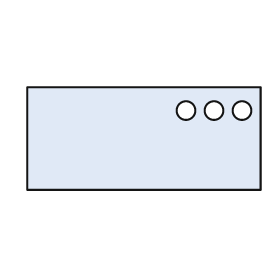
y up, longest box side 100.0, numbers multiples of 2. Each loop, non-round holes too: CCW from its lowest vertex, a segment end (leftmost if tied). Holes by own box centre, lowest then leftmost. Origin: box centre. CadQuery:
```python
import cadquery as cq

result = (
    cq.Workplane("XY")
    .moveTo(-50.0, -22.0)
    .lineTo(50.0, -22.0)
    .lineTo(50.0, 22.0)
    .lineTo(-50.0, 22.0)
    .close()
    .moveTo(18.0, 12.0)
    .circle(4.0)
    .moveTo(30.0, 12.0)
    .circle(4.0)
    .moveTo(42.0, 12.0)
    .circle(4.0)
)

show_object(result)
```